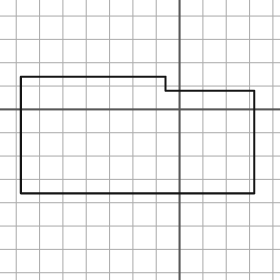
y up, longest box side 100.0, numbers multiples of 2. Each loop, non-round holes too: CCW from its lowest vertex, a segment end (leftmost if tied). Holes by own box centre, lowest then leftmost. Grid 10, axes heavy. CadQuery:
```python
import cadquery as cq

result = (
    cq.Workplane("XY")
    .moveTo(-68.0, -36.0)
    .lineTo(32.0, -36.0)
    .lineTo(32.0, 8.0)
    .lineTo(-6.0, 8.0)
    .lineTo(-6.0, 14.0)
    .lineTo(-68.0, 14.0)
    .close()
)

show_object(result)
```